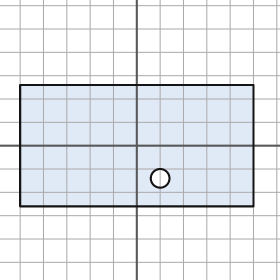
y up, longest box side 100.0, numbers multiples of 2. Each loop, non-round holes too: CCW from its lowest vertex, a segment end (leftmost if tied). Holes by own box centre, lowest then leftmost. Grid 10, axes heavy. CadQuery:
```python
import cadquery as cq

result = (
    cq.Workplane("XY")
    .moveTo(-50.0, -26.0)
    .lineTo(50.0, -26.0)
    .lineTo(50.0, 26.0)
    .lineTo(-50.0, 26.0)
    .close()
    .moveTo(10.0, -14.0)
    .circle(4.0)
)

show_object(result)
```